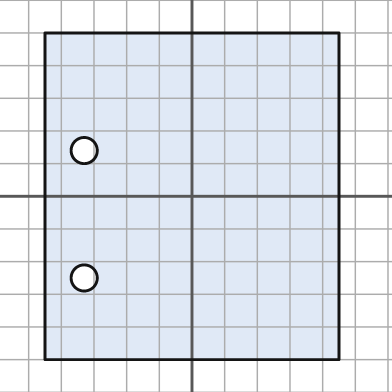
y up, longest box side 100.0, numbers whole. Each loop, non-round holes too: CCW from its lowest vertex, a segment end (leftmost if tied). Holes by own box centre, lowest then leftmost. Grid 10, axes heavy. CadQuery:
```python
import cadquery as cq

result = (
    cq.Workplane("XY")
    .moveTo(-45.0, -50.0)
    .lineTo(45.0, -50.0)
    .lineTo(45.0, 50.0)
    .lineTo(-45.0, 50.0)
    .close()
    .moveTo(-33.0, -25.0)
    .circle(4.0)
    .moveTo(-33.0, 14.0)
    .circle(4.0)
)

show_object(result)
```